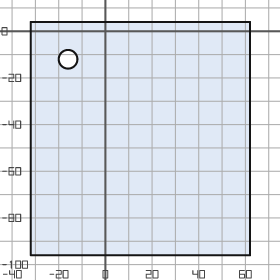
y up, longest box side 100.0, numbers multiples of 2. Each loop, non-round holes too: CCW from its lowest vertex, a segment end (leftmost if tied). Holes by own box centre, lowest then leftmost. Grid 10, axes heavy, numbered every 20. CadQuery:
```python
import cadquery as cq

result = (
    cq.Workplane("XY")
    .moveTo(-32.0, -96.0)
    .lineTo(62.0, -96.0)
    .lineTo(62.0, 4.0)
    .lineTo(-32.0, 4.0)
    .close()
    .moveTo(-16.0, -12.0)
    .circle(4.0)
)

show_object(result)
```